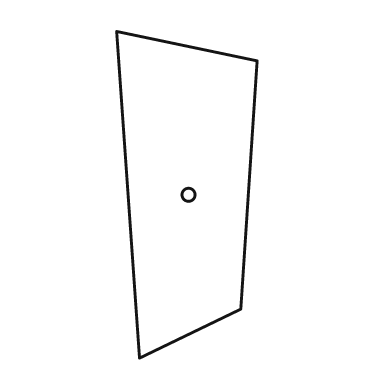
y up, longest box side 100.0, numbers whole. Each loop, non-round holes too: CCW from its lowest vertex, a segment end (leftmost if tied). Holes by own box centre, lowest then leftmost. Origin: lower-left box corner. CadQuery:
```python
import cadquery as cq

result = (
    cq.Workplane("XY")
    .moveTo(7.0, 0.0)
    .lineTo(38.0, 15.0)
    .lineTo(43.0, 91.0)
    .lineTo(0.0, 100.0)
    .close()
    .moveTo(22.0, 50.0)
    .circle(2.0)
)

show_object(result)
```